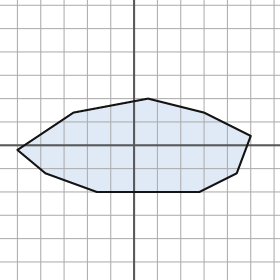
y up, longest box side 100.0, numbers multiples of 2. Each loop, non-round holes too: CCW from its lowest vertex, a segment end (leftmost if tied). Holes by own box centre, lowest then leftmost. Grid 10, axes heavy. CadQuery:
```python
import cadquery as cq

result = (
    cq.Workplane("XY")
    .moveTo(-16.0, -20.0)
    .lineTo(28.0, -20.0)
    .lineTo(44.0, -12.0)
    .lineTo(50.0, 4.0)
    .lineTo(30.0, 14.0)
    .lineTo(6.0, 20.0)
    .lineTo(-26.0, 14.0)
    .lineTo(-50.0, -2.0)
    .lineTo(-38.0, -12.0)
    .close()
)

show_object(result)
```